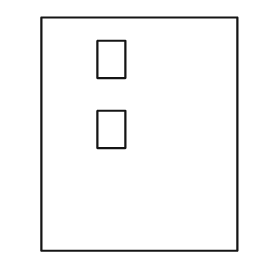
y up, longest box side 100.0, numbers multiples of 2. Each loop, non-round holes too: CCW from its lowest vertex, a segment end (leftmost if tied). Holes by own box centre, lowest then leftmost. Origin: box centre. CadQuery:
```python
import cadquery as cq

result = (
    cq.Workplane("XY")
    .moveTo(-42.0, -50.0)
    .lineTo(42.0, -50.0)
    .lineTo(42.0, 50.0)
    .lineTo(-42.0, 50.0)
    .close()
    .moveTo(-18.0, -6.0)
    .lineTo(-6.0, -6.0)
    .lineTo(-6.0, 10.0)
    .lineTo(-18.0, 10.0)
    .close()
    .moveTo(-18.0, 24.0)
    .lineTo(-6.0, 24.0)
    .lineTo(-6.0, 40.0)
    .lineTo(-18.0, 40.0)
    .close()
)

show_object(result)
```